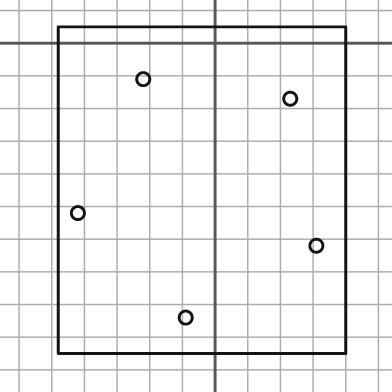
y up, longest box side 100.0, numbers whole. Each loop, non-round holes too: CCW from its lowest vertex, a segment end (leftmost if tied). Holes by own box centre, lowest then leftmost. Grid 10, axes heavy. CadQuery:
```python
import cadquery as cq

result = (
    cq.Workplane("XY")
    .moveTo(-48.0, -95.0)
    .lineTo(40.0, -95.0)
    .lineTo(40.0, 5.0)
    .lineTo(-48.0, 5.0)
    .close()
    .moveTo(-9.0, -84.0)
    .circle(2.0)
    .moveTo(31.0, -62.0)
    .circle(2.0)
    .moveTo(-42.0, -52.0)
    .circle(2.0)
    .moveTo(23.0, -17.0)
    .circle(2.0)
    .moveTo(-22.0, -11.0)
    .circle(2.0)
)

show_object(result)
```